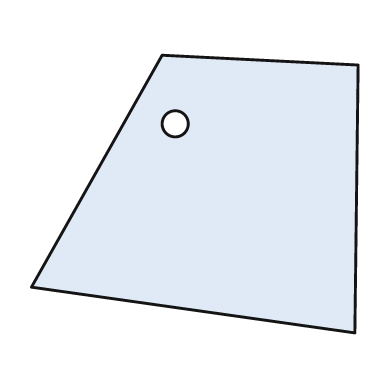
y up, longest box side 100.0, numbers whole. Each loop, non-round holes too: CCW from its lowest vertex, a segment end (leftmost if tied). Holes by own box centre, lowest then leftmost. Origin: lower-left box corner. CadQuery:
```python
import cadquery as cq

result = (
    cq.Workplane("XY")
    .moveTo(99.0, 0.0)
    .lineTo(100.0, 82.0)
    .lineTo(40.0, 85.0)
    .lineTo(0.0, 14.0)
    .close()
    .moveTo(44.0, 64.0)
    .circle(4.0)
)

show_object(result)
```